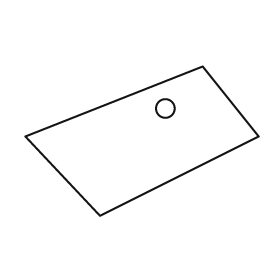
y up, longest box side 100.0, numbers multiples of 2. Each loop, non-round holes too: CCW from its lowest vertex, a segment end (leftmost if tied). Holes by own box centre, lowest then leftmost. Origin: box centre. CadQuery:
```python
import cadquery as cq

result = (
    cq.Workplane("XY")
    .moveTo(-18.0, -32.0)
    .lineTo(50.0, 2.0)
    .lineTo(26.0, 32.0)
    .lineTo(-50.0, 2.0)
    .close()
    .moveTo(10.0, 14.0)
    .circle(4.0)
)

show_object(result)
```